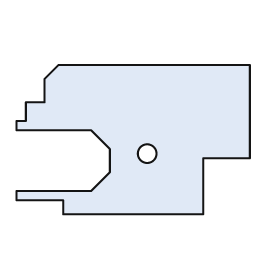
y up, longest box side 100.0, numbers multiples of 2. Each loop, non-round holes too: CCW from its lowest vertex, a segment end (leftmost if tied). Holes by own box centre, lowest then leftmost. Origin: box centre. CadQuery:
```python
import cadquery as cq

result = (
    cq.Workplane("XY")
    .moveTo(-30.0, -32.0)
    .lineTo(30.0, -32.0)
    .lineTo(30.0, -8.0)
    .lineTo(50.0, -8.0)
    .lineTo(50.0, 32.0)
    .lineTo(-32.0, 32.0)
    .lineTo(-38.0, 26.0)
    .lineTo(-38.0, 16.0)
    .lineTo(-46.0, 16.0)
    .lineTo(-46.0, 8.0)
    .lineTo(-50.0, 8.0)
    .lineTo(-50.0, 4.0)
    .lineTo(-18.0, 4.0)
    .lineTo(-10.0, -4.0)
    .lineTo(-10.0, -14.0)
    .lineTo(-18.0, -22.0)
    .lineTo(-50.0, -22.0)
    .lineTo(-50.0, -26.0)
    .lineTo(-30.0, -26.0)
    .close()
    .moveTo(6.0, -6.0)
    .circle(4.0)
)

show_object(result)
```